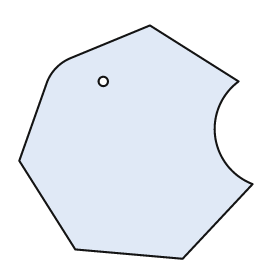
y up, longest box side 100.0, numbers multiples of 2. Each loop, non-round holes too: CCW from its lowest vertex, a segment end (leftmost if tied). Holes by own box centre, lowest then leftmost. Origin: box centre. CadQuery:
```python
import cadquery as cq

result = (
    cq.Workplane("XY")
    .moveTo(20.0, -50.0)
    .lineTo(50.0, -18.0)
    .threePointArc((34.0, 2.0), (44.0, 26.0))
    .lineTo(6.0, 50.0)
    .lineTo(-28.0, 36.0)
    .threePointArc((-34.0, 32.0), (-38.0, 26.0))
    .lineTo(-50.0, -8.0)
    .lineTo(-26.0, -46.0)
    .close()
    .moveTo(-14.0, 26.0)
    .circle(2.0)
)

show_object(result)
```